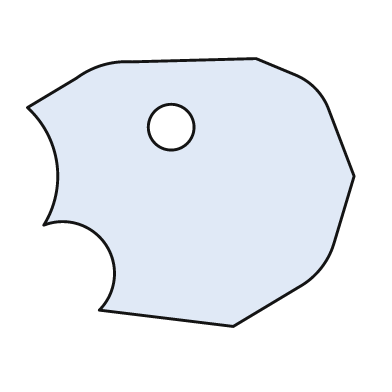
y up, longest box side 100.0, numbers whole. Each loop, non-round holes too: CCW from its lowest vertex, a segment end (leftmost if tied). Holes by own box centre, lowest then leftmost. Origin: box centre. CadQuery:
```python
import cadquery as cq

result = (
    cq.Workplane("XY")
    .moveTo(13.0, -41.0)
    .lineTo(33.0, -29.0)
    .threePointArc((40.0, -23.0), (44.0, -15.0))
    .lineTo(50.0, 5.0)
    .lineTo(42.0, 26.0)
    .threePointArc((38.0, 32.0), (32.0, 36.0))
    .lineTo(20.0, 41.0)
    .lineTo(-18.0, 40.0)
    .threePointArc((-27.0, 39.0), (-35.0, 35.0))
    .lineTo(-50.0, 26.0)
    .threePointArc((-41.0, 9.0), (-45.0, -10.0))
    .threePointArc((-26.0, -16.0), (-28.0, -36.0))
    .close()
    .moveTo(-6.0, 20.0)
    .circle(7.0)
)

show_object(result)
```